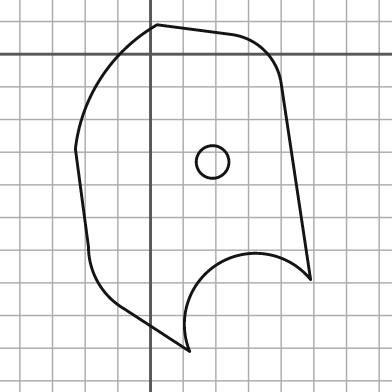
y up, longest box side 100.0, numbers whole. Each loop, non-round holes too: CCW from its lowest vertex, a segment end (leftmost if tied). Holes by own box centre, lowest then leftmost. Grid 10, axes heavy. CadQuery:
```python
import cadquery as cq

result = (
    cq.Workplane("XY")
    .moveTo(12.0, -91.0)
    .threePointArc((21.0, -64.0), (49.0, -69.0))
    .lineTo(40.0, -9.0)
    .threePointArc((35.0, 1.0), (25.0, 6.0))
    .lineTo(2.0, 9.0)
    .threePointArc((-15.0, -7.0), (-23.0, -29.0))
    .lineTo(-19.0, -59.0)
    .threePointArc((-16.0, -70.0), (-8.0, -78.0))
    .close()
    .moveTo(19.0, -33.0)
    .circle(5.0)
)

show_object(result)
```